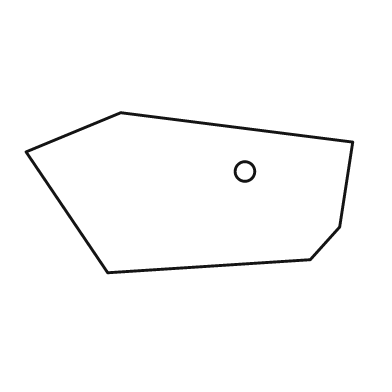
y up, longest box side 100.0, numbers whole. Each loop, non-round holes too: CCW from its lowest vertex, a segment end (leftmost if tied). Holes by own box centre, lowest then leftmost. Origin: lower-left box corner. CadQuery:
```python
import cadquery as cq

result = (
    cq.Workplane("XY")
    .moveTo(25.0, 0.0)
    .lineTo(87.0, 4.0)
    .lineTo(96.0, 14.0)
    .lineTo(100.0, 40.0)
    .lineTo(29.0, 49.0)
    .lineTo(0.0, 37.0)
    .close()
    .moveTo(67.0, 31.0)
    .circle(3.0)
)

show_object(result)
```